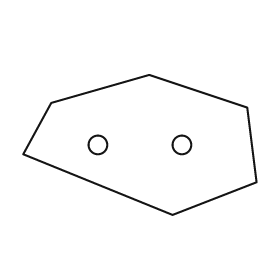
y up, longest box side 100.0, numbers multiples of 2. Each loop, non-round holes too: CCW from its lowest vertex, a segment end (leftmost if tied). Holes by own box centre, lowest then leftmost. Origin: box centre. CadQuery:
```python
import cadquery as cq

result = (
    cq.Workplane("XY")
    .moveTo(14.0, -30.0)
    .lineTo(50.0, -16.0)
    .lineTo(46.0, 16.0)
    .lineTo(4.0, 30.0)
    .lineTo(-38.0, 18.0)
    .lineTo(-50.0, -4.0)
    .close()
    .moveTo(-18.0, 0.0)
    .circle(4.0)
    .moveTo(18.0, 0.0)
    .circle(4.0)
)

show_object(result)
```